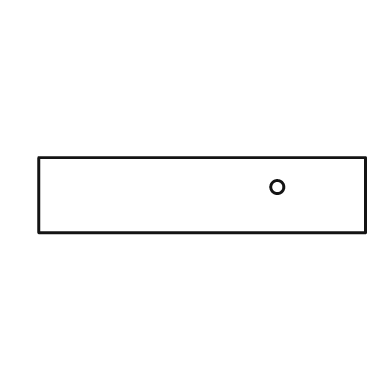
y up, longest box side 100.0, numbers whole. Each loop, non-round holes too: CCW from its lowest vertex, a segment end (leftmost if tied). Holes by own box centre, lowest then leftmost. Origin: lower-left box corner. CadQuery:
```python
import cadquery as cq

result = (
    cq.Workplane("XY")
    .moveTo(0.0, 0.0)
    .lineTo(100.0, 0.0)
    .lineTo(100.0, 23.0)
    .lineTo(0.0, 23.0)
    .close()
    .moveTo(73.0, 14.0)
    .circle(2.0)
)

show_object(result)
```